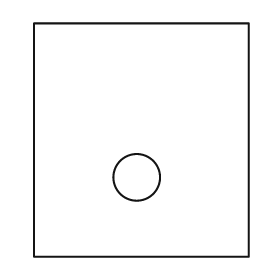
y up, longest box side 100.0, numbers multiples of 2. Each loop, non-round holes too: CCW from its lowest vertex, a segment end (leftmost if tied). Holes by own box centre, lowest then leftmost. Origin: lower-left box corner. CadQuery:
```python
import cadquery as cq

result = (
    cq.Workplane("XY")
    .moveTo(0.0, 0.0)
    .lineTo(92.0, 0.0)
    .lineTo(92.0, 100.0)
    .lineTo(0.0, 100.0)
    .close()
    .moveTo(44.0, 34.0)
    .circle(10.0)
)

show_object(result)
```